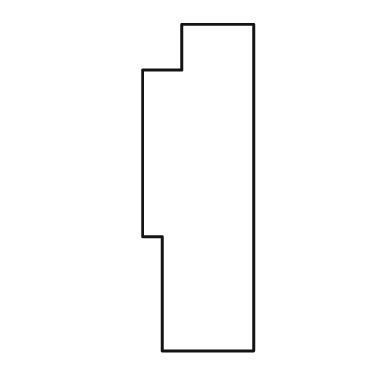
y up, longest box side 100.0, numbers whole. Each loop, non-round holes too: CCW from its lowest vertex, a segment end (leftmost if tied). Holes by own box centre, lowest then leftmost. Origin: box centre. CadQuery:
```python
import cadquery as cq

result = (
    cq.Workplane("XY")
    .moveTo(-11.0, -50.0)
    .lineTo(17.0, -50.0)
    .lineTo(17.0, 50.0)
    .lineTo(-5.0, 50.0)
    .lineTo(-5.0, 36.0)
    .lineTo(-17.0, 36.0)
    .lineTo(-17.0, -15.0)
    .lineTo(-11.0, -15.0)
    .close()
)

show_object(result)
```